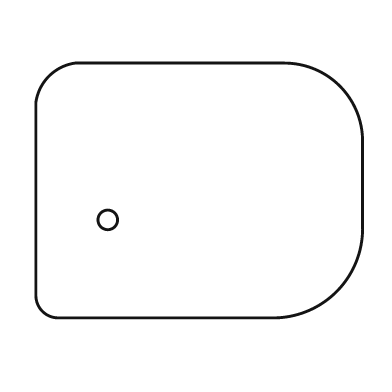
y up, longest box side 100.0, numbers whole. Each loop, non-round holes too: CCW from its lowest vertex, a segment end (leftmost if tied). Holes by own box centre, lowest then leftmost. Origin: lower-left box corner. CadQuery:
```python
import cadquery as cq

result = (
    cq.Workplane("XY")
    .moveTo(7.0, 0.0)
    .lineTo(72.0, 0.0)
    .threePointArc((92.0, 8.0), (100.0, 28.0))
    .lineTo(100.0, 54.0)
    .threePointArc((93.0, 71.0), (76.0, 78.0))
    .lineTo(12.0, 78.0)
    .threePointArc((4.0, 74.0), (0.0, 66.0))
    .lineTo(0.0, 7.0)
    .threePointArc((2.0, 2.0), (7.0, 0.0))
    .close()
    .moveTo(22.0, 30.0)
    .circle(3.0)
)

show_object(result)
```